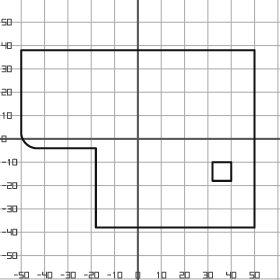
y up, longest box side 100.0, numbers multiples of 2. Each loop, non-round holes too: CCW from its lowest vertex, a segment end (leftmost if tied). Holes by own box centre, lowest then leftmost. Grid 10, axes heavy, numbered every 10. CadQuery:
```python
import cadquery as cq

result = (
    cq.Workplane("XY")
    .moveTo(-18.0, -38.0)
    .lineTo(50.0, -38.0)
    .lineTo(50.0, 38.0)
    .lineTo(-50.0, 38.0)
    .lineTo(-50.0, 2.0)
    .threePointArc((-48.0, -2.0), (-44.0, -4.0))
    .lineTo(-18.0, -4.0)
    .close()
    .moveTo(32.0, -18.0)
    .lineTo(40.0, -18.0)
    .lineTo(40.0, -10.0)
    .lineTo(32.0, -10.0)
    .close()
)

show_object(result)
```